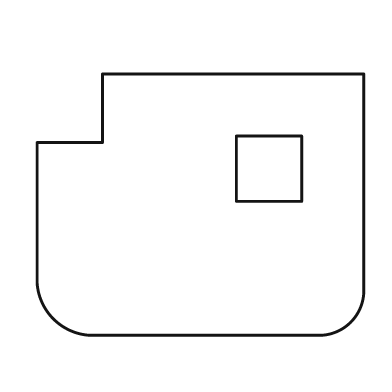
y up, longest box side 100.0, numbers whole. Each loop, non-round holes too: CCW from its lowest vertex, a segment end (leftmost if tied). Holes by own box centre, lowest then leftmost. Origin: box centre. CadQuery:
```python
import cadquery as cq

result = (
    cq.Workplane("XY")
    .moveTo(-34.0, -40.0)
    .lineTo(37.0, -40.0)
    .threePointArc((46.0, -36.0), (50.0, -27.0))
    .lineTo(50.0, 40.0)
    .lineTo(-30.0, 40.0)
    .lineTo(-30.0, 19.0)
    .lineTo(-50.0, 19.0)
    .lineTo(-50.0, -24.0)
    .threePointArc((-45.0, -35.0), (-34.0, -40.0))
    .close()
    .moveTo(11.0, 1.0)
    .lineTo(31.0, 1.0)
    .lineTo(31.0, 21.0)
    .lineTo(11.0, 21.0)
    .close()
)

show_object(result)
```